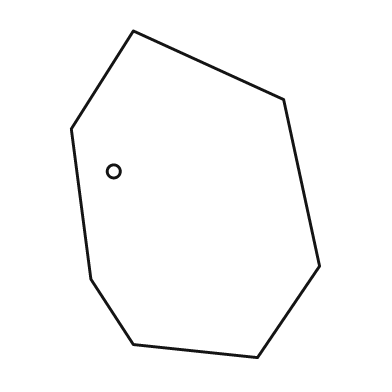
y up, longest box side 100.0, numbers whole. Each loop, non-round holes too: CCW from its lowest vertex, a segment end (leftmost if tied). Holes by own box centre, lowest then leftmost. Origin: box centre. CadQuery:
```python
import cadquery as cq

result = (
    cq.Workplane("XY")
    .moveTo(19.0, -50.0)
    .lineTo(38.0, -22.0)
    .lineTo(27.0, 29.0)
    .lineTo(-19.0, 50.0)
    .lineTo(-38.0, 20.0)
    .lineTo(-32.0, -26.0)
    .lineTo(-19.0, -46.0)
    .close()
    .moveTo(-25.0, 7.0)
    .circle(2.0)
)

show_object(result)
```